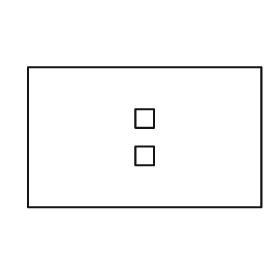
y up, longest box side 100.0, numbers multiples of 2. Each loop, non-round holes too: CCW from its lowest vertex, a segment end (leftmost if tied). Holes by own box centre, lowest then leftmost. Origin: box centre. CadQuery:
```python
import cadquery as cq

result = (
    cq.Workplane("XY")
    .moveTo(-50.0, -30.0)
    .lineTo(50.0, -30.0)
    .lineTo(50.0, 30.0)
    .lineTo(-50.0, 30.0)
    .close()
    .moveTo(-4.0, -12.0)
    .lineTo(4.0, -12.0)
    .lineTo(4.0, -4.0)
    .lineTo(-4.0, -4.0)
    .close()
    .moveTo(-4.0, 4.0)
    .lineTo(4.0, 4.0)
    .lineTo(4.0, 12.0)
    .lineTo(-4.0, 12.0)
    .close()
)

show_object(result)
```